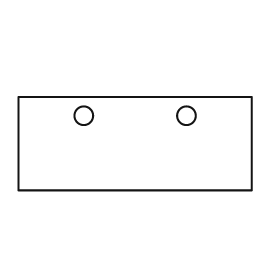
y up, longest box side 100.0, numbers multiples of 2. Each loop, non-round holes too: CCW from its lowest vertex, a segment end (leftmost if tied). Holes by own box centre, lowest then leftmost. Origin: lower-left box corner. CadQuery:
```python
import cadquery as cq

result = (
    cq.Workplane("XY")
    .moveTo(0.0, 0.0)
    .lineTo(100.0, 0.0)
    .lineTo(100.0, 40.0)
    .lineTo(0.0, 40.0)
    .close()
    .moveTo(28.0, 32.0)
    .circle(4.0)
    .moveTo(72.0, 32.0)
    .circle(4.0)
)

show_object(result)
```